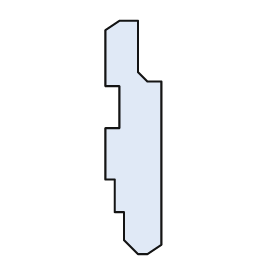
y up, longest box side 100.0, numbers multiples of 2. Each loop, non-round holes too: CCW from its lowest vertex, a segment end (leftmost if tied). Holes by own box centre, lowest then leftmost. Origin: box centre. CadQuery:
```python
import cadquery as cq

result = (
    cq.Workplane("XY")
    .moveTo(2.0, -50.0)
    .lineTo(6.0, -50.0)
    .lineTo(12.0, -46.0)
    .lineTo(12.0, 24.0)
    .lineTo(6.0, 24.0)
    .lineTo(2.0, 28.0)
    .lineTo(2.0, 50.0)
    .lineTo(-6.0, 50.0)
    .lineTo(-12.0, 46.0)
    .lineTo(-12.0, 22.0)
    .lineTo(-6.0, 22.0)
    .lineTo(-6.0, 4.0)
    .lineTo(-12.0, 4.0)
    .lineTo(-12.0, -18.0)
    .lineTo(-8.0, -18.0)
    .lineTo(-8.0, -32.0)
    .lineTo(-4.0, -32.0)
    .lineTo(-4.0, -44.0)
    .close()
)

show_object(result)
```